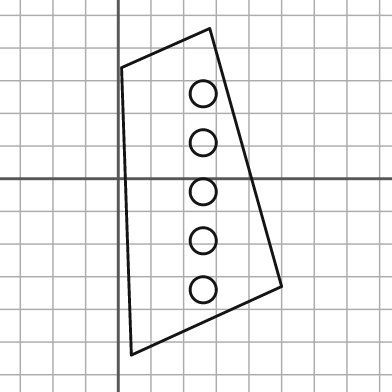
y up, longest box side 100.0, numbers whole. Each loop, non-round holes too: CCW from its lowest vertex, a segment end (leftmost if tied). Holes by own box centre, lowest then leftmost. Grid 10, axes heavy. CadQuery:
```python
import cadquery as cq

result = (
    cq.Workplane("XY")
    .moveTo(4.0, -54.0)
    .lineTo(50.0, -33.0)
    .lineTo(28.0, 46.0)
    .lineTo(1.0, 34.0)
    .close()
    .moveTo(26.0, -34.0)
    .circle(4.0)
    .moveTo(26.0, -19.0)
    .circle(4.0)
    .moveTo(26.0, -4.0)
    .circle(4.0)
    .moveTo(26.0, 11.0)
    .circle(4.0)
    .moveTo(26.0, 26.0)
    .circle(4.0)
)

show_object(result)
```